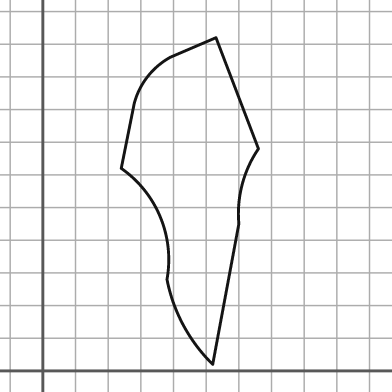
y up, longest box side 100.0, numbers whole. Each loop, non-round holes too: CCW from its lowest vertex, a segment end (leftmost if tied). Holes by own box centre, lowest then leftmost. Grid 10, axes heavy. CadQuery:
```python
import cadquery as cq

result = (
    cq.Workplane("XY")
    .moveTo(52.0, 2.0)
    .lineTo(60.0, 45.0)
    .threePointArc((61.0, 57.0), (66.0, 68.0))
    .lineTo(53.0, 102.0)
    .lineTo(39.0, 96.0)
    .threePointArc((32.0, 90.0), (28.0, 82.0))
    .lineTo(24.0, 62.0)
    .threePointArc((36.0, 47.0), (38.0, 28.0))
    .threePointArc((43.0, 14.0), (52.0, 2.0))
    .close()
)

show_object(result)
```